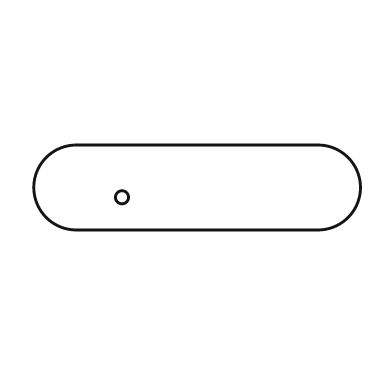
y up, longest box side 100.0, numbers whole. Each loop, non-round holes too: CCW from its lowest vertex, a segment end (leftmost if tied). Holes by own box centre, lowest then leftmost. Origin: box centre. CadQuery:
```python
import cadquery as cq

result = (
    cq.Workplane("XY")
    .moveTo(-37.0, -13.0)
    .lineTo(37.0, -13.0)
    .threePointArc((50.0, 0.0), (37.0, 13.0))
    .lineTo(-37.0, 13.0)
    .threePointArc((-50.0, 0.0), (-37.0, -13.0))
    .close()
    .moveTo(-23.0, -3.0)
    .circle(2.0)
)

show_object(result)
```